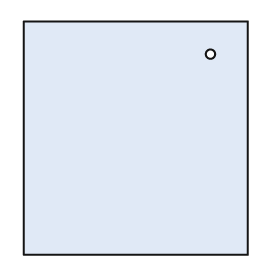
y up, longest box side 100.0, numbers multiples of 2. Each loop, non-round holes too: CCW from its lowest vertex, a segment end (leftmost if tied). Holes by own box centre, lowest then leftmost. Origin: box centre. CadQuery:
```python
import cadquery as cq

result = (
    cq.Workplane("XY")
    .moveTo(-48.0, -50.0)
    .lineTo(48.0, -50.0)
    .lineTo(48.0, 50.0)
    .lineTo(-48.0, 50.0)
    .close()
    .moveTo(32.0, 36.0)
    .circle(2.0)
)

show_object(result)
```